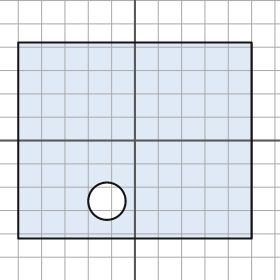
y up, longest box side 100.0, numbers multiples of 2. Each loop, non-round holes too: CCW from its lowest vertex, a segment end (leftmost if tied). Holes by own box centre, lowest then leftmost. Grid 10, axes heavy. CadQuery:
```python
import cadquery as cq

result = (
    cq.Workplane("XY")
    .moveTo(-50.0, -42.0)
    .lineTo(50.0, -42.0)
    .lineTo(50.0, 42.0)
    .lineTo(-50.0, 42.0)
    .close()
    .moveTo(-12.0, -26.0)
    .circle(8.0)
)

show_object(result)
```